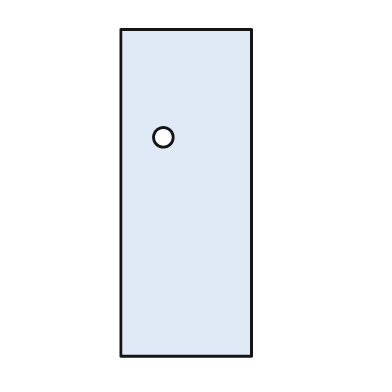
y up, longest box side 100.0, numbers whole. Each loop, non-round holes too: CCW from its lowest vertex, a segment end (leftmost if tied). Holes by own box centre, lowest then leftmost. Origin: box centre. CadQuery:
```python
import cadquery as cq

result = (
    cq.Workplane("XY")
    .moveTo(-20.0, -50.0)
    .lineTo(20.0, -50.0)
    .lineTo(20.0, 50.0)
    .lineTo(-20.0, 50.0)
    .close()
    .moveTo(-7.0, 17.0)
    .circle(3.0)
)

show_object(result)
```